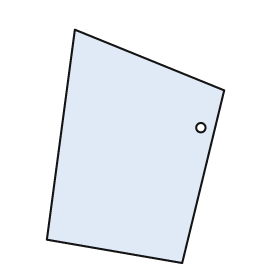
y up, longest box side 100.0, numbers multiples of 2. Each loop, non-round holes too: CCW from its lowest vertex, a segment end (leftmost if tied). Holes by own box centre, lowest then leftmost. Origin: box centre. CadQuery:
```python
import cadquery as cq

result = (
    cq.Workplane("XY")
    .moveTo(20.0, -50.0)
    .lineTo(38.0, 24.0)
    .lineTo(-26.0, 50.0)
    .lineTo(-38.0, -40.0)
    .close()
    .moveTo(28.0, 8.0)
    .circle(2.0)
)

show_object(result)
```